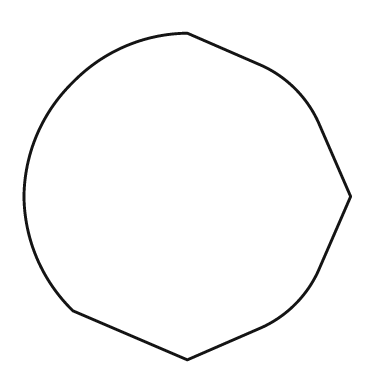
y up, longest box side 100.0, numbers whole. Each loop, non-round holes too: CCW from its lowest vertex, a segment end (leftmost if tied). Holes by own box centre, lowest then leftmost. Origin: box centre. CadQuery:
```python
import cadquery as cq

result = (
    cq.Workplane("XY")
    .moveTo(0.0, -50.0)
    .lineTo(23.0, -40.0)
    .threePointArc((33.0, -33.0), (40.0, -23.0))
    .lineTo(50.0, 0.0)
    .lineTo(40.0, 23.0)
    .threePointArc((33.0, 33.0), (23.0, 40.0))
    .lineTo(0.0, 50.0)
    .threePointArc((-19.0, 46.0), (-35.0, 35.0))
    .threePointArc((-46.0, 19.0), (-50.0, 0.0))
    .threePointArc((-46.0, -19.0), (-35.0, -35.0))
    .close()
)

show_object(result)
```